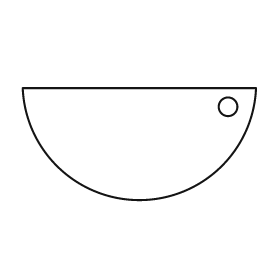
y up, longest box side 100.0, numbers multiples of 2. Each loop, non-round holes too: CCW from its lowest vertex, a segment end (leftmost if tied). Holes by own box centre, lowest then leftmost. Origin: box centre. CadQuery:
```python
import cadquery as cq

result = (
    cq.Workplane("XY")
    .moveTo(-50.0, 24.0)
    .threePointArc((0.0, -24.0), (50.0, 24.0))
    .close()
    .moveTo(38.0, 16.0)
    .circle(4.0)
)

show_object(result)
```